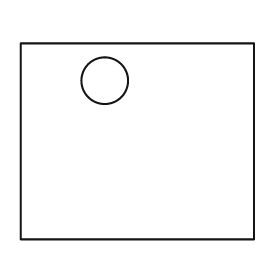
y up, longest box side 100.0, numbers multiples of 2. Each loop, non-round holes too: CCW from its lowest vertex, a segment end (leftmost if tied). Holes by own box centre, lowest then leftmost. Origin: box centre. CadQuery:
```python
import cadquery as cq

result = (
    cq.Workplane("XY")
    .moveTo(-50.0, -42.0)
    .lineTo(50.0, -42.0)
    .lineTo(50.0, 42.0)
    .lineTo(-50.0, 42.0)
    .close()
    .moveTo(-14.0, 26.0)
    .circle(10.0)
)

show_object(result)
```